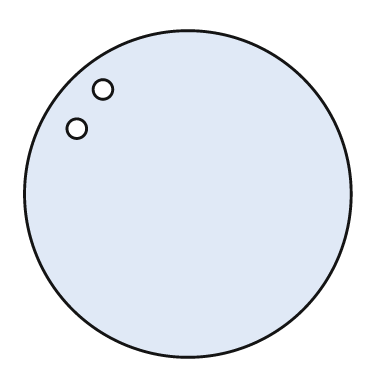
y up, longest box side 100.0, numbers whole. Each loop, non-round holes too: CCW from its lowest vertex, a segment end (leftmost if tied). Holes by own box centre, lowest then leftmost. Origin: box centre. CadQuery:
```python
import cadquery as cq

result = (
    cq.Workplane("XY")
    .moveTo(0.0, 0.0)
    .circle(50.0)
    .moveTo(-34.0, 20.0)
    .circle(3.0)
    .moveTo(-26.0, 32.0)
    .circle(3.0)
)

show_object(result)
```